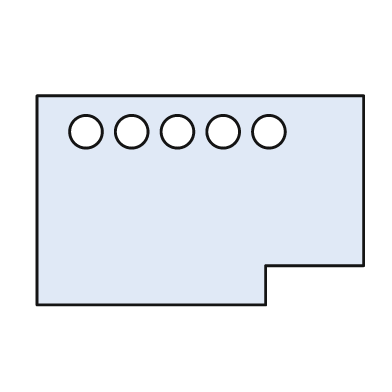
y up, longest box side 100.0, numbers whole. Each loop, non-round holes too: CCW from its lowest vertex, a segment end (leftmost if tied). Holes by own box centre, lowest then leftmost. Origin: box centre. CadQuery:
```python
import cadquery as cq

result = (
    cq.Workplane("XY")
    .moveTo(-50.0, -32.0)
    .lineTo(20.0, -32.0)
    .lineTo(20.0, -20.0)
    .lineTo(50.0, -20.0)
    .lineTo(50.0, 32.0)
    .lineTo(-50.0, 32.0)
    .close()
    .moveTo(-35.0, 21.0)
    .circle(5.0)
    .moveTo(-21.0, 21.0)
    .circle(5.0)
    .moveTo(-7.0, 21.0)
    .circle(5.0)
    .moveTo(7.0, 21.0)
    .circle(5.0)
    .moveTo(21.0, 21.0)
    .circle(5.0)
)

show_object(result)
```